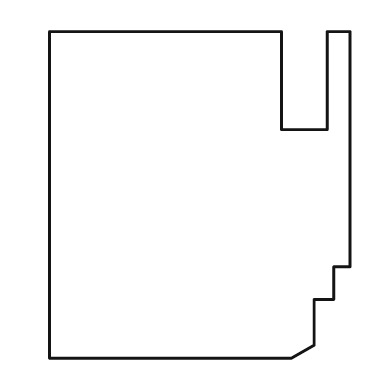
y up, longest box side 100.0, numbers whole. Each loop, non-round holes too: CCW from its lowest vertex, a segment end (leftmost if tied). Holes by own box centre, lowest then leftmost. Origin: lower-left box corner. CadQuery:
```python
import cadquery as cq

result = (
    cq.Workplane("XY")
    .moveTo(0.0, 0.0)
    .lineTo(74.0, 0.0)
    .lineTo(81.0, 4.0)
    .lineTo(81.0, 18.0)
    .lineTo(87.0, 18.0)
    .lineTo(87.0, 28.0)
    .lineTo(92.0, 28.0)
    .lineTo(92.0, 100.0)
    .lineTo(85.0, 100.0)
    .lineTo(85.0, 70.0)
    .lineTo(71.0, 70.0)
    .lineTo(71.0, 100.0)
    .lineTo(0.0, 100.0)
    .close()
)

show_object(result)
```